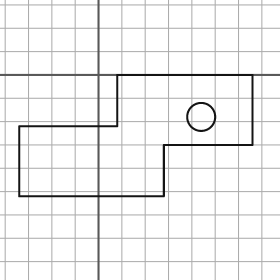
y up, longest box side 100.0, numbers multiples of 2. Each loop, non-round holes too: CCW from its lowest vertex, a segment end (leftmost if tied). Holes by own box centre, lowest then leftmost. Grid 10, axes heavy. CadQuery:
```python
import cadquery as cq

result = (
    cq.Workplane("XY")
    .moveTo(-34.0, -52.0)
    .lineTo(28.0, -52.0)
    .lineTo(28.0, -30.0)
    .lineTo(66.0, -30.0)
    .lineTo(66.0, 0.0)
    .lineTo(8.0, 0.0)
    .lineTo(8.0, -22.0)
    .lineTo(-34.0, -22.0)
    .close()
    .moveTo(44.0, -18.0)
    .circle(6.0)
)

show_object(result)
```